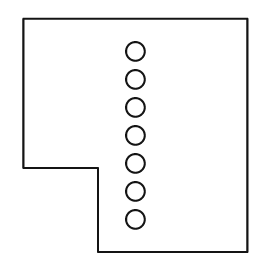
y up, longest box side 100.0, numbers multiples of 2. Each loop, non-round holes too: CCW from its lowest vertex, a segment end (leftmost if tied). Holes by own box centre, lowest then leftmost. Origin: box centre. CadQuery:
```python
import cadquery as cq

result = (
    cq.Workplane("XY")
    .moveTo(-16.0, -50.0)
    .lineTo(48.0, -50.0)
    .lineTo(48.0, 50.0)
    .lineTo(-48.0, 50.0)
    .lineTo(-48.0, -14.0)
    .lineTo(-16.0, -14.0)
    .close()
    .moveTo(0.0, -36.0)
    .circle(4.0)
    .moveTo(0.0, -24.0)
    .circle(4.0)
    .moveTo(0.0, -12.0)
    .circle(4.0)
    .moveTo(0.0, 0.0)
    .circle(4.0)
    .moveTo(0.0, 12.0)
    .circle(4.0)
    .moveTo(0.0, 24.0)
    .circle(4.0)
    .moveTo(0.0, 36.0)
    .circle(4.0)
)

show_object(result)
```